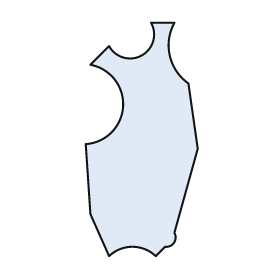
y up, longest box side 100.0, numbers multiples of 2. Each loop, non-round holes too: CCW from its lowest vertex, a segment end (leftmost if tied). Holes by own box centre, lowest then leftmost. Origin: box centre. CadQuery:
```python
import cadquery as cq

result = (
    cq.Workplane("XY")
    .moveTo(-14.0, -50.0)
    .threePointArc((-4.0, -46.0), (6.0, -50.0))
    .lineTo(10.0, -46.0)
    .threePointArc((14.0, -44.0), (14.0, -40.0))
    .lineTo(24.0, -4.0)
    .lineTo(20.0, 24.0)
    .threePointArc((12.0, 36.0), (14.0, 50.0))
    .lineTo(4.0, 50.0)
    .threePointArc((0.0, 36.0), (-14.0, 40.0))
    .lineTo(-22.0, 32.0)
    .threePointArc((-8.0, 14.0), (-24.0, -2.0))
    .lineTo(-22.0, -32.0)
    .close()
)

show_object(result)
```